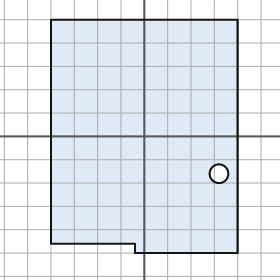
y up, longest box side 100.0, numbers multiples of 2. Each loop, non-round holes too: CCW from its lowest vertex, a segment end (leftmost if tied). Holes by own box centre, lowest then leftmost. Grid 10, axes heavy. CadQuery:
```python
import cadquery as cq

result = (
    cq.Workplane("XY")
    .moveTo(-4.0, -50.0)
    .lineTo(40.0, -50.0)
    .lineTo(40.0, 50.0)
    .lineTo(-40.0, 50.0)
    .lineTo(-40.0, -46.0)
    .lineTo(-4.0, -46.0)
    .close()
    .moveTo(32.0, -16.0)
    .circle(4.0)
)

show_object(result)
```